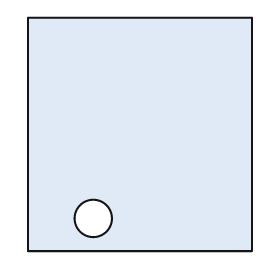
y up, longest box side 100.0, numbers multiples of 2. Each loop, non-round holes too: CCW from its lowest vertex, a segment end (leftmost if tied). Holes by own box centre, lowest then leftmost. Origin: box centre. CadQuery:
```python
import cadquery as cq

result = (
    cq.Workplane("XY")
    .moveTo(-48.0, -50.0)
    .lineTo(48.0, -50.0)
    .lineTo(48.0, 50.0)
    .lineTo(-48.0, 50.0)
    .close()
    .moveTo(-20.0, -36.0)
    .circle(8.0)
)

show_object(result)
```